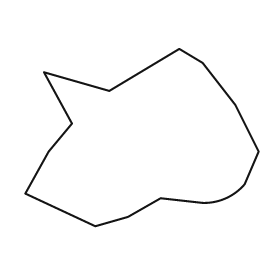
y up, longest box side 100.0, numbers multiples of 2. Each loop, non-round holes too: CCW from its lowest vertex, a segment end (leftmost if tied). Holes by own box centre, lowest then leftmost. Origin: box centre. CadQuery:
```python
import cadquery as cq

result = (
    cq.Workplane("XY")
    .moveTo(-20.0, -38.0)
    .lineTo(-6.0, -34.0)
    .lineTo(8.0, -26.0)
    .lineTo(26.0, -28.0)
    .threePointArc((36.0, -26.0), (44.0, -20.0))
    .lineTo(50.0, -6.0)
    .lineTo(40.0, 14.0)
    .lineTo(26.0, 32.0)
    .lineTo(16.0, 38.0)
    .lineTo(-14.0, 20.0)
    .lineTo(-42.0, 28.0)
    .lineTo(-30.0, 6.0)
    .lineTo(-40.0, -6.0)
    .lineTo(-50.0, -24.0)
    .close()
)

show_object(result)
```